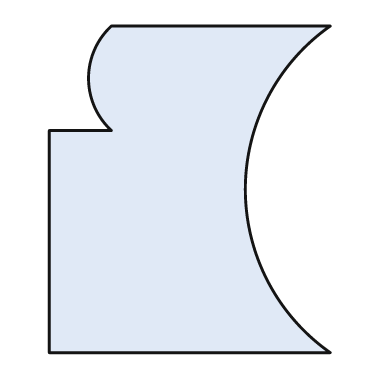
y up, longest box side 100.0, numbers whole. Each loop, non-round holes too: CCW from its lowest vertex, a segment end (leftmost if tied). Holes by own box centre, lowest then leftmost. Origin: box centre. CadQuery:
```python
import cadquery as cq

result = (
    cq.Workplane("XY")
    .moveTo(-43.0, -50.0)
    .lineTo(43.0, -50.0)
    .threePointArc((17.0, 0.0), (43.0, 50.0))
    .lineTo(-24.0, 50.0)
    .threePointArc((-31.0, 34.0), (-24.0, 18.0))
    .lineTo(-43.0, 18.0)
    .close()
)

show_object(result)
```